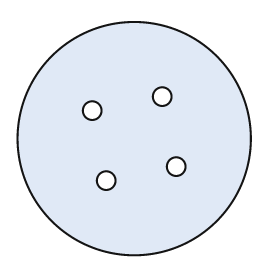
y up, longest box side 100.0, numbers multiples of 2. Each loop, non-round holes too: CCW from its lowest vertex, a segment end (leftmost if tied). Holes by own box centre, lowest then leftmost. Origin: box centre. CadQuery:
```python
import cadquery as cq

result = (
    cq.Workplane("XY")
    .moveTo(0.0, 0.0)
    .circle(50.0)
    .moveTo(-12.0, -18.0)
    .circle(4.0)
    .moveTo(18.0, -12.0)
    .circle(4.0)
    .moveTo(-18.0, 12.0)
    .circle(4.0)
    .moveTo(12.0, 18.0)
    .circle(4.0)
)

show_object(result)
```